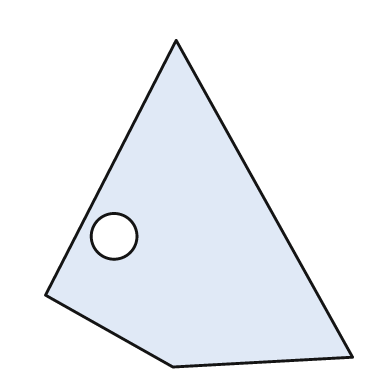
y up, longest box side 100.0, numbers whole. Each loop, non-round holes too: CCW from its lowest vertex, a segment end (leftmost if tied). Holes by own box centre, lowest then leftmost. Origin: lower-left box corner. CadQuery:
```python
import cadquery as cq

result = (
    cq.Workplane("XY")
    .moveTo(39.0, 0.0)
    .lineTo(94.0, 3.0)
    .lineTo(40.0, 100.0)
    .lineTo(0.0, 22.0)
    .close()
    .moveTo(21.0, 40.0)
    .circle(7.0)
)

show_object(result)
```